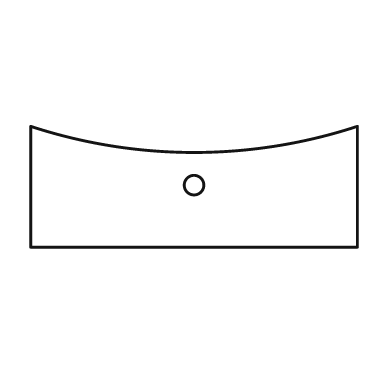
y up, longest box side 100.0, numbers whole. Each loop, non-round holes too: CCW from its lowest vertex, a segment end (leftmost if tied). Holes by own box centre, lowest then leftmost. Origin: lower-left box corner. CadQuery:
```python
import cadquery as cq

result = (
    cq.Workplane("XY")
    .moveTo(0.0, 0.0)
    .lineTo(100.0, 0.0)
    .lineTo(100.0, 37.0)
    .threePointArc((50.0, 29.0), (0.0, 37.0))
    .close()
    .moveTo(50.0, 19.0)
    .circle(3.0)
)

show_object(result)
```